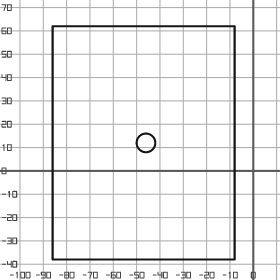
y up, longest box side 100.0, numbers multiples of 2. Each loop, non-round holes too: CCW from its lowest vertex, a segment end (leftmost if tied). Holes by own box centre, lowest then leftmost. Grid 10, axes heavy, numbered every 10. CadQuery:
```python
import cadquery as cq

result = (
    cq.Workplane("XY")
    .moveTo(-86.0, -38.0)
    .lineTo(-8.0, -38.0)
    .lineTo(-8.0, 62.0)
    .lineTo(-86.0, 62.0)
    .close()
    .moveTo(-46.0, 12.0)
    .circle(4.0)
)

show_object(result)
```